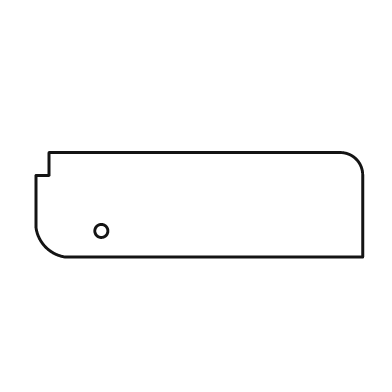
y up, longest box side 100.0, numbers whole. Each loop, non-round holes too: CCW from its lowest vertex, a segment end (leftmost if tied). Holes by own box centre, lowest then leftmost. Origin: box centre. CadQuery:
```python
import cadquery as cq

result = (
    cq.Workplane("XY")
    .moveTo(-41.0, -16.0)
    .lineTo(50.0, -16.0)
    .lineTo(50.0, 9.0)
    .threePointArc((48.0, 14.0), (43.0, 16.0))
    .lineTo(-46.0, 16.0)
    .lineTo(-46.0, 9.0)
    .lineTo(-50.0, 9.0)
    .lineTo(-50.0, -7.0)
    .threePointArc((-47.0, -13.0), (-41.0, -16.0))
    .close()
    .moveTo(-30.0, -8.0)
    .circle(2.0)
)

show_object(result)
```